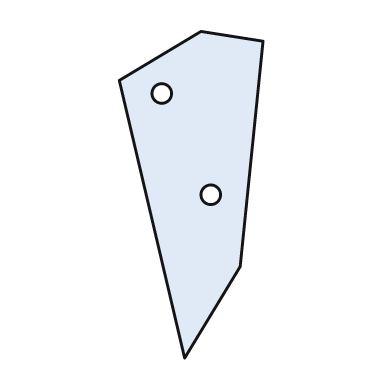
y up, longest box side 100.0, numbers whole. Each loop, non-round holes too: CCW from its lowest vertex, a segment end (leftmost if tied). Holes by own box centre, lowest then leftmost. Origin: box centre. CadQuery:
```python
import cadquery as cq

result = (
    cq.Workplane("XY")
    .moveTo(-2.0, -50.0)
    .lineTo(15.0, -22.0)
    .lineTo(22.0, 47.0)
    .lineTo(3.0, 50.0)
    .lineTo(-22.0, 35.0)
    .close()
    .moveTo(6.0, 0.0)
    .circle(3.0)
    .moveTo(-9.0, 31.0)
    .circle(3.0)
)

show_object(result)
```